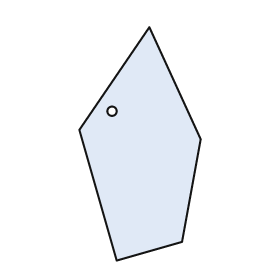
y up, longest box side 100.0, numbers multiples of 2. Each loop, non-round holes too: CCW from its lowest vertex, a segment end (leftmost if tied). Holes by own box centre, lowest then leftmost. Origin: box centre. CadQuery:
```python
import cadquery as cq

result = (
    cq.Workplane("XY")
    .moveTo(-10.0, -50.0)
    .lineTo(18.0, -42.0)
    .lineTo(26.0, 2.0)
    .lineTo(4.0, 50.0)
    .lineTo(-26.0, 6.0)
    .close()
    .moveTo(-12.0, 14.0)
    .circle(2.0)
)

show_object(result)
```